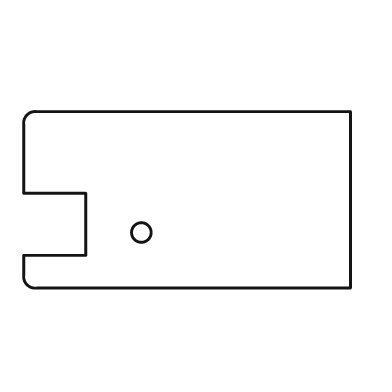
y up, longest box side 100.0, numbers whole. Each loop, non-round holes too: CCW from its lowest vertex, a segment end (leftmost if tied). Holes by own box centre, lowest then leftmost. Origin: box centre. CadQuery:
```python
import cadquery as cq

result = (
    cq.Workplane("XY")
    .moveTo(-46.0, -27.0)
    .lineTo(50.0, -27.0)
    .lineTo(50.0, 27.0)
    .lineTo(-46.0, 27.0)
    .threePointArc((-49.0, 26.0), (-50.0, 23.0))
    .lineTo(-50.0, 2.0)
    .lineTo(-31.0, 2.0)
    .lineTo(-31.0, -17.0)
    .lineTo(-50.0, -17.0)
    .lineTo(-50.0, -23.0)
    .threePointArc((-49.0, -26.0), (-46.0, -27.0))
    .close()
    .moveTo(-14.0, -10.0)
    .circle(3.0)
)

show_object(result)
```